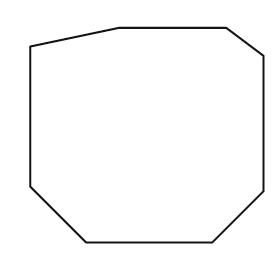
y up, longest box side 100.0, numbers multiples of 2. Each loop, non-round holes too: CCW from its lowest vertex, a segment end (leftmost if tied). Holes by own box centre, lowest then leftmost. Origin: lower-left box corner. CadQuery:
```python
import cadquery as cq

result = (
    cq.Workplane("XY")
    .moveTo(24.0, 0.0)
    .lineTo(78.0, 0.0)
    .lineTo(100.0, 22.0)
    .lineTo(100.0, 80.0)
    .lineTo(84.0, 92.0)
    .lineTo(38.0, 92.0)
    .lineTo(0.0, 84.0)
    .lineTo(0.0, 24.0)
    .close()
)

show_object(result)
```